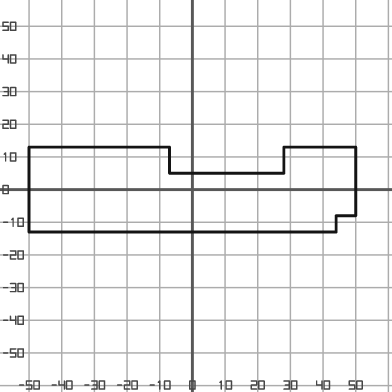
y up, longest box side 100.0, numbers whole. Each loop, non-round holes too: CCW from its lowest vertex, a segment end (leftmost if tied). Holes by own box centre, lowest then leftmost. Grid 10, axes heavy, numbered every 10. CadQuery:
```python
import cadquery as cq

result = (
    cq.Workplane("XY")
    .moveTo(-50.0, -13.0)
    .lineTo(44.0, -13.0)
    .lineTo(44.0, -8.0)
    .lineTo(50.0, -8.0)
    .lineTo(50.0, 13.0)
    .lineTo(28.0, 13.0)
    .lineTo(28.0, 5.0)
    .lineTo(-7.0, 5.0)
    .lineTo(-7.0, 13.0)
    .lineTo(-50.0, 13.0)
    .close()
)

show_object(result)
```